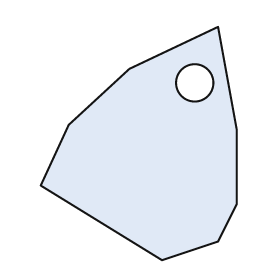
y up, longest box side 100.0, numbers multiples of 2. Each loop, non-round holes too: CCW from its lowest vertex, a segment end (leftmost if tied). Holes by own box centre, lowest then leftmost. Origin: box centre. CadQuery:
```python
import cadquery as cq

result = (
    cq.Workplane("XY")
    .moveTo(10.0, -50.0)
    .lineTo(34.0, -42.0)
    .lineTo(42.0, -26.0)
    .lineTo(42.0, 6.0)
    .lineTo(34.0, 50.0)
    .lineTo(-4.0, 32.0)
    .lineTo(-30.0, 8.0)
    .lineTo(-42.0, -18.0)
    .close()
    .moveTo(24.0, 26.0)
    .circle(8.0)
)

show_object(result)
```